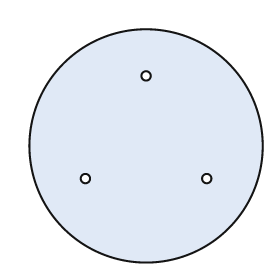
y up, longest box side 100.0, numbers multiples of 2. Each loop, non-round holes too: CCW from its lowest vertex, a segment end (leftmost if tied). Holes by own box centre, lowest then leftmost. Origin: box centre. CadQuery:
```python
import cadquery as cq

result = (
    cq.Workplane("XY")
    .moveTo(0.0, 0.0)
    .circle(50.0)
    .moveTo(-26.0, -14.0)
    .circle(2.0)
    .moveTo(26.0, -14.0)
    .circle(2.0)
    .moveTo(0.0, 30.0)
    .circle(2.0)
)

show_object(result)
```